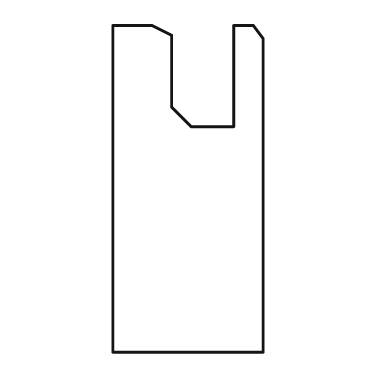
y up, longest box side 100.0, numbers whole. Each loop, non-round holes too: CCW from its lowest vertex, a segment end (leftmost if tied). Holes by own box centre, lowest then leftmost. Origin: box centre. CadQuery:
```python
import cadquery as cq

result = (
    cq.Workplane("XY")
    .moveTo(-23.0, -50.0)
    .lineTo(23.0, -50.0)
    .lineTo(23.0, 46.0)
    .lineTo(20.0, 50.0)
    .lineTo(14.0, 50.0)
    .lineTo(14.0, 19.0)
    .lineTo(1.0, 19.0)
    .lineTo(-5.0, 25.0)
    .lineTo(-5.0, 47.0)
    .lineTo(-11.0, 50.0)
    .lineTo(-23.0, 50.0)
    .close()
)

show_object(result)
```